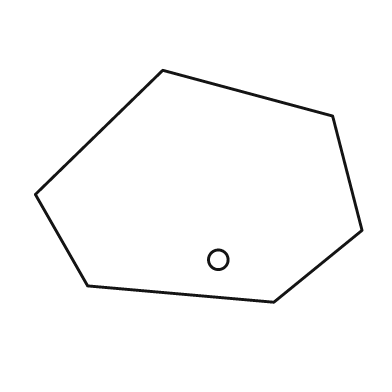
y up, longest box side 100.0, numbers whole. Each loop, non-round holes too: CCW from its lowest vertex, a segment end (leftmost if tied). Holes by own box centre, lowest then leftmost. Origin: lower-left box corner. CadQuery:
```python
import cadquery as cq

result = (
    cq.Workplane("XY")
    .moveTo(73.0, 0.0)
    .lineTo(100.0, 22.0)
    .lineTo(91.0, 57.0)
    .lineTo(39.0, 71.0)
    .lineTo(0.0, 33.0)
    .lineTo(16.0, 5.0)
    .close()
    .moveTo(56.0, 13.0)
    .circle(3.0)
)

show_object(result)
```